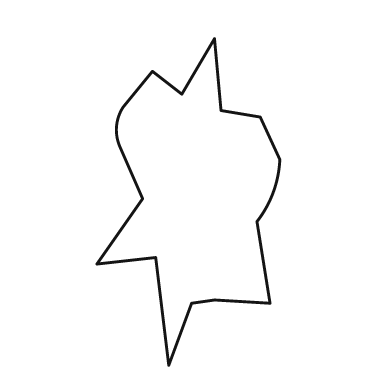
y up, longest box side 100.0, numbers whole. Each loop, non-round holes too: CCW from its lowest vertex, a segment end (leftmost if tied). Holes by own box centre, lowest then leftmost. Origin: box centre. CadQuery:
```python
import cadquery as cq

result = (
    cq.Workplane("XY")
    .moveTo(-6.0, -50.0)
    .lineTo(1.0, -31.0)
    .lineTo(8.0, -30.0)
    .lineTo(25.0, -31.0)
    .lineTo(21.0, -6.0)
    .threePointArc((26.0, 3.0), (28.0, 13.0))
    .lineTo(22.0, 26.0)
    .lineTo(10.0, 28.0)
    .lineTo(8.0, 50.0)
    .lineTo(-2.0, 33.0)
    .lineTo(-11.0, 40.0)
    .lineTo(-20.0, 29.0)
    .threePointArc((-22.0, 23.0), (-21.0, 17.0))
    .lineTo(-14.0, 1.0)
    .lineTo(-28.0, -19.0)
    .lineTo(-10.0, -17.0)
    .close()
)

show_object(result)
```